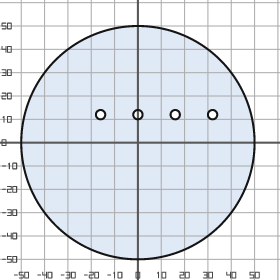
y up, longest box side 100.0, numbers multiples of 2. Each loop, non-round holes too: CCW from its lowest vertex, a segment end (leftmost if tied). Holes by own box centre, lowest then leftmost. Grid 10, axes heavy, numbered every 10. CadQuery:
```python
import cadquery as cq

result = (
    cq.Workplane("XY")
    .moveTo(0.0, 0.0)
    .circle(50.0)
    .moveTo(-16.0, 12.0)
    .circle(2.0)
    .moveTo(0.0, 12.0)
    .circle(2.0)
    .moveTo(16.0, 12.0)
    .circle(2.0)
    .moveTo(32.0, 12.0)
    .circle(2.0)
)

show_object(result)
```